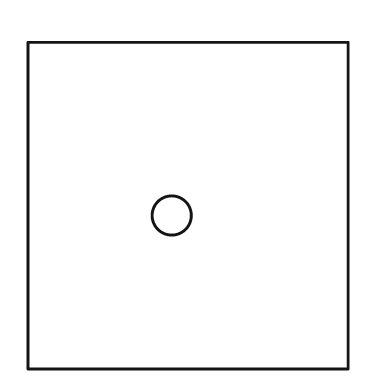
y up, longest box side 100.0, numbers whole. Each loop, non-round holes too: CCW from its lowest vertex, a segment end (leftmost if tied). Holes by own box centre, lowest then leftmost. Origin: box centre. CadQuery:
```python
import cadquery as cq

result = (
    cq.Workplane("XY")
    .moveTo(-49.0, -50.0)
    .lineTo(49.0, -50.0)
    .lineTo(49.0, 50.0)
    .lineTo(-49.0, 50.0)
    .close()
    .moveTo(-5.0, -3.0)
    .circle(6.0)
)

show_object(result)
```